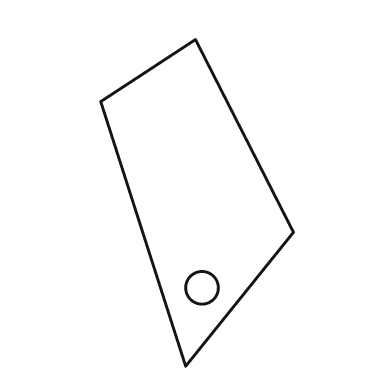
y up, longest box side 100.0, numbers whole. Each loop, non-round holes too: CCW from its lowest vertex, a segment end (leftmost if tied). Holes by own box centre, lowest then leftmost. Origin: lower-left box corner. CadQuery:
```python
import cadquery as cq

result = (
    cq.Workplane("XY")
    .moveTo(26.0, 0.0)
    .lineTo(59.0, 41.0)
    .lineTo(29.0, 100.0)
    .lineTo(0.0, 81.0)
    .close()
    .moveTo(31.0, 24.0)
    .circle(5.0)
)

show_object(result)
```